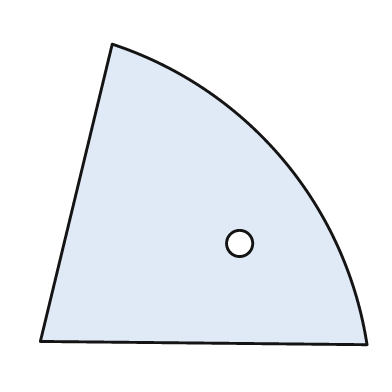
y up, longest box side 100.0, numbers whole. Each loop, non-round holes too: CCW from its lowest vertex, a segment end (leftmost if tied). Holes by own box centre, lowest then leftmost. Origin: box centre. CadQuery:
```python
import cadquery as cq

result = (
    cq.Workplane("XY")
    .moveTo(50.0, -46.0)
    .threePointArc((24.0, 11.0), (-28.0, 46.0))
    .lineTo(-50.0, -45.0)
    .close()
    .moveTo(11.0, -15.0)
    .circle(4.0)
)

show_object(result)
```